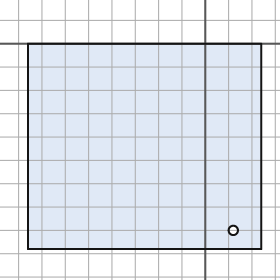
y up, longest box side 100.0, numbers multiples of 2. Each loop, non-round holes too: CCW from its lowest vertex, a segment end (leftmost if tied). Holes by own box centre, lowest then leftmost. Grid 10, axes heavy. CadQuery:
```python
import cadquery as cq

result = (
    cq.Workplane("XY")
    .moveTo(-76.0, -88.0)
    .lineTo(24.0, -88.0)
    .lineTo(24.0, 0.0)
    .lineTo(-76.0, 0.0)
    .close()
    .moveTo(12.0, -80.0)
    .circle(2.0)
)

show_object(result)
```